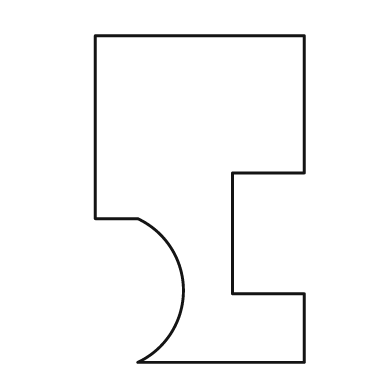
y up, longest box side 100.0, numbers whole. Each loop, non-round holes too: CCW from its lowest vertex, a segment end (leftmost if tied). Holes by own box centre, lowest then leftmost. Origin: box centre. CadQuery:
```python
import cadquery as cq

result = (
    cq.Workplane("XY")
    .moveTo(-19.0, -50.0)
    .lineTo(32.0, -50.0)
    .lineTo(32.0, -29.0)
    .lineTo(10.0, -29.0)
    .lineTo(10.0, 8.0)
    .lineTo(32.0, 8.0)
    .lineTo(32.0, 50.0)
    .lineTo(-32.0, 50.0)
    .lineTo(-32.0, -6.0)
    .lineTo(-19.0, -6.0)
    .threePointArc((-5.0, -28.0), (-19.0, -50.0))
    .close()
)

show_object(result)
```